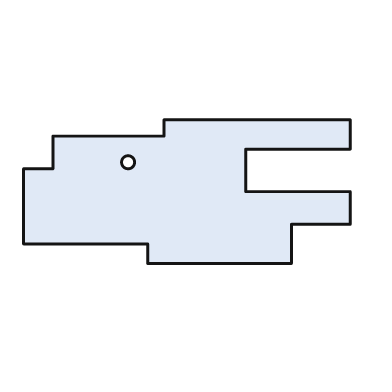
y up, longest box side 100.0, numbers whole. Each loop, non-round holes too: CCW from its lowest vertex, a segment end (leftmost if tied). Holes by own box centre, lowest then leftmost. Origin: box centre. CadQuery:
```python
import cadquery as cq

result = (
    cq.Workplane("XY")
    .moveTo(-12.0, -22.0)
    .lineTo(32.0, -22.0)
    .lineTo(32.0, -10.0)
    .lineTo(50.0, -10.0)
    .lineTo(50.0, 0.0)
    .lineTo(18.0, 0.0)
    .lineTo(18.0, 13.0)
    .lineTo(50.0, 13.0)
    .lineTo(50.0, 22.0)
    .lineTo(-7.0, 22.0)
    .lineTo(-7.0, 17.0)
    .lineTo(-41.0, 17.0)
    .lineTo(-41.0, 7.0)
    .lineTo(-50.0, 7.0)
    .lineTo(-50.0, -16.0)
    .lineTo(-12.0, -16.0)
    .close()
    .moveTo(-18.0, 9.0)
    .circle(2.0)
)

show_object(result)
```